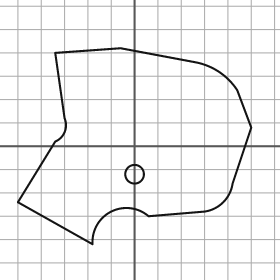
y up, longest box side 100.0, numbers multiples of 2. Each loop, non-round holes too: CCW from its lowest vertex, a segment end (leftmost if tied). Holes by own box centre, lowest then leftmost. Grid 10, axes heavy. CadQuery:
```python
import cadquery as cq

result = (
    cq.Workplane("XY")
    .moveTo(-18.0, -42.0)
    .threePointArc((-10.0, -28.0), (6.0, -30.0))
    .lineTo(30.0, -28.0)
    .threePointArc((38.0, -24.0), (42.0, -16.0))
    .lineTo(50.0, 8.0)
    .lineTo(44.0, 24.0)
    .threePointArc((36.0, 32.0), (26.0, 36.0))
    .lineTo(-6.0, 42.0)
    .lineTo(-34.0, 40.0)
    .lineTo(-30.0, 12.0)
    .threePointArc((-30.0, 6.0), (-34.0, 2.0))
    .lineTo(-50.0, -24.0)
    .close()
    .moveTo(0.0, -12.0)
    .circle(4.0)
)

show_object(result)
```